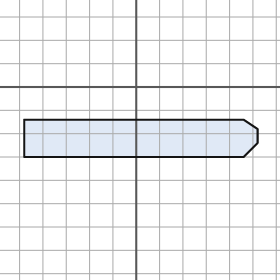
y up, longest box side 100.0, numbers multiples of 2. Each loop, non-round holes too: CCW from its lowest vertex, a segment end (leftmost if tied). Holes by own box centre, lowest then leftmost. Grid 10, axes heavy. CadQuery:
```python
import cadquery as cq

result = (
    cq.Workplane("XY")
    .moveTo(-48.0, -30.0)
    .lineTo(46.0, -30.0)
    .lineTo(52.0, -24.0)
    .lineTo(52.0, -18.0)
    .lineTo(46.0, -14.0)
    .lineTo(-48.0, -14.0)
    .close()
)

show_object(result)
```